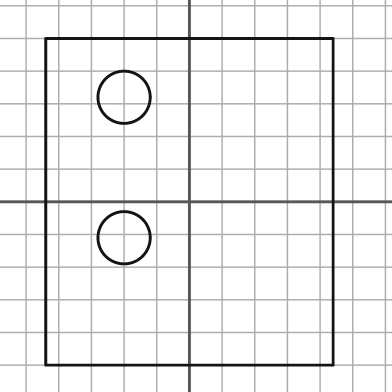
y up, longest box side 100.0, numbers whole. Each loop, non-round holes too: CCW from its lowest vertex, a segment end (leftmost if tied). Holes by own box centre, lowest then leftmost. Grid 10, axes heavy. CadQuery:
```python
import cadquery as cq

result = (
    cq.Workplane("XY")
    .moveTo(-44.0, -50.0)
    .lineTo(44.0, -50.0)
    .lineTo(44.0, 50.0)
    .lineTo(-44.0, 50.0)
    .close()
    .moveTo(-20.0, -11.0)
    .circle(8.0)
    .moveTo(-20.0, 32.0)
    .circle(8.0)
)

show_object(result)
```